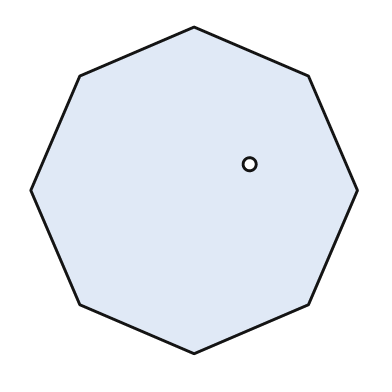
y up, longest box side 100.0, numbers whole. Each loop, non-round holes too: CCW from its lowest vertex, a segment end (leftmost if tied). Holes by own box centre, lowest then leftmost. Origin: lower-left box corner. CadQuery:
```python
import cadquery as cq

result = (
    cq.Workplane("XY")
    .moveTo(50.0, 0.0)
    .lineTo(85.0, 15.0)
    .lineTo(100.0, 50.0)
    .lineTo(85.0, 85.0)
    .lineTo(50.0, 100.0)
    .lineTo(15.0, 85.0)
    .lineTo(0.0, 50.0)
    .lineTo(15.0, 15.0)
    .close()
    .moveTo(67.0, 58.0)
    .circle(2.0)
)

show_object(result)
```